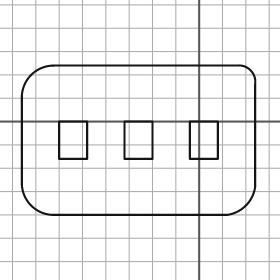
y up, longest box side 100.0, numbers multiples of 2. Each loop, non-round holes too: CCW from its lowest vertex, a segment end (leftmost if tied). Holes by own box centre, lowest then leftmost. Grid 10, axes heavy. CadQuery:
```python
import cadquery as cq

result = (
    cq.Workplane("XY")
    .moveTo(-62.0, -40.0)
    .lineTo(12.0, -40.0)
    .threePointArc((20.0, -36.0), (24.0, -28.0))
    .lineTo(24.0, 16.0)
    .threePointArc((22.0, 22.0), (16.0, 24.0))
    .lineTo(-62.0, 24.0)
    .threePointArc((-72.0, 20.0), (-76.0, 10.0))
    .lineTo(-76.0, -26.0)
    .threePointArc((-72.0, -36.0), (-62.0, -40.0))
    .close()
    .moveTo(-60.0, -16.0)
    .lineTo(-48.0, -16.0)
    .lineTo(-48.0, 0.0)
    .lineTo(-60.0, 0.0)
    .close()
    .moveTo(-32.0, -16.0)
    .lineTo(-20.0, -16.0)
    .lineTo(-20.0, 0.0)
    .lineTo(-32.0, 0.0)
    .close()
    .moveTo(-4.0, -16.0)
    .lineTo(8.0, -16.0)
    .lineTo(8.0, 0.0)
    .lineTo(-4.0, 0.0)
    .close()
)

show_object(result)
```